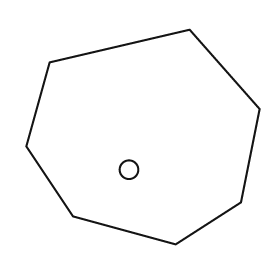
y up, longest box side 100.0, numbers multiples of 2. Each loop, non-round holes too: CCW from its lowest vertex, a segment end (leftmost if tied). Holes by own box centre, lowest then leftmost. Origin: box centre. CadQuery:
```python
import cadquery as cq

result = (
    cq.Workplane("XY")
    .moveTo(14.0, -46.0)
    .lineTo(42.0, -28.0)
    .lineTo(50.0, 12.0)
    .lineTo(20.0, 46.0)
    .lineTo(-40.0, 32.0)
    .lineTo(-50.0, -4.0)
    .lineTo(-30.0, -34.0)
    .close()
    .moveTo(-6.0, -14.0)
    .circle(4.0)
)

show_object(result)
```